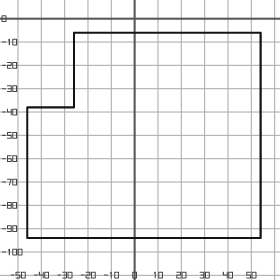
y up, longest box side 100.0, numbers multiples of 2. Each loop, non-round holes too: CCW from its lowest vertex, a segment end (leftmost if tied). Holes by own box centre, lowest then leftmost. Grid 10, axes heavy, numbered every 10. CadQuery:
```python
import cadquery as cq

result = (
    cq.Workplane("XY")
    .moveTo(-46.0, -94.0)
    .lineTo(54.0, -94.0)
    .lineTo(54.0, -6.0)
    .lineTo(-26.0, -6.0)
    .lineTo(-26.0, -38.0)
    .lineTo(-46.0, -38.0)
    .close()
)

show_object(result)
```